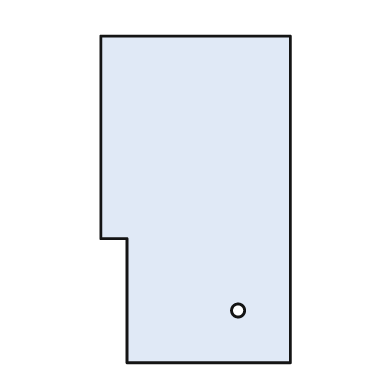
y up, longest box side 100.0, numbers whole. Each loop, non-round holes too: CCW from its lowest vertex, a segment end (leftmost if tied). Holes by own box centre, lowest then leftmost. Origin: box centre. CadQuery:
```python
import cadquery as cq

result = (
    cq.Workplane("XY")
    .moveTo(-21.0, -50.0)
    .lineTo(29.0, -50.0)
    .lineTo(29.0, 50.0)
    .lineTo(-29.0, 50.0)
    .lineTo(-29.0, -12.0)
    .lineTo(-21.0, -12.0)
    .close()
    .moveTo(13.0, -34.0)
    .circle(2.0)
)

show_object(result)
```